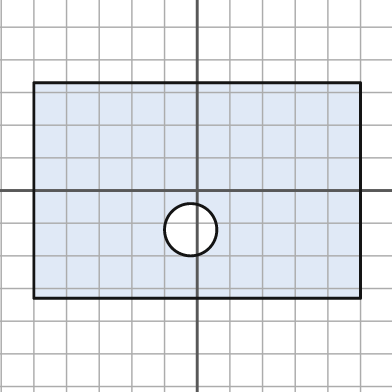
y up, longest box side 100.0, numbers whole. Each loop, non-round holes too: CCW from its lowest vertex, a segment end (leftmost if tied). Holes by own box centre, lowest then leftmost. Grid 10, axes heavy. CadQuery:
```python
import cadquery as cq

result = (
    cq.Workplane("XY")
    .moveTo(-50.0, -33.0)
    .lineTo(50.0, -33.0)
    .lineTo(50.0, 33.0)
    .lineTo(-50.0, 33.0)
    .close()
    .moveTo(-2.0, -12.0)
    .circle(8.0)
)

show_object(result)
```